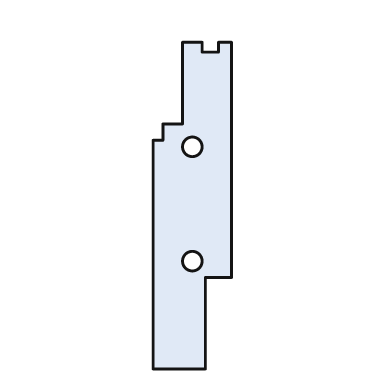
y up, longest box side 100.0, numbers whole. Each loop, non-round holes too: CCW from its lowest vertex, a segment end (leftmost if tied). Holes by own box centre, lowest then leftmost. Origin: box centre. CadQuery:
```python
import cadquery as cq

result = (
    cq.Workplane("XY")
    .moveTo(-12.0, -50.0)
    .lineTo(4.0, -50.0)
    .lineTo(4.0, -22.0)
    .lineTo(12.0, -22.0)
    .lineTo(12.0, 50.0)
    .lineTo(8.0, 50.0)
    .lineTo(8.0, 47.0)
    .lineTo(3.0, 47.0)
    .lineTo(3.0, 50.0)
    .lineTo(-3.0, 50.0)
    .lineTo(-3.0, 25.0)
    .lineTo(-9.0, 25.0)
    .lineTo(-9.0, 20.0)
    .lineTo(-12.0, 20.0)
    .close()
    .moveTo(0.0, -17.0)
    .circle(3.0)
    .moveTo(0.0, 18.0)
    .circle(3.0)
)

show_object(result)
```